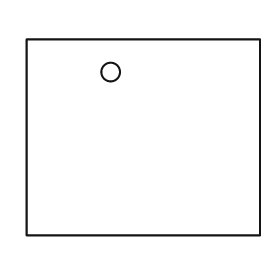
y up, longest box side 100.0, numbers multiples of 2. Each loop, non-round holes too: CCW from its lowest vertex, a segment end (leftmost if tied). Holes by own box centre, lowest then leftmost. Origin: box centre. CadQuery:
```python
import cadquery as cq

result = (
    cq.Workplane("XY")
    .moveTo(-50.0, -42.0)
    .lineTo(50.0, -42.0)
    .lineTo(50.0, 42.0)
    .lineTo(-50.0, 42.0)
    .close()
    .moveTo(-14.0, 28.0)
    .circle(4.0)
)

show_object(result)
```